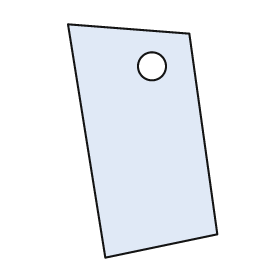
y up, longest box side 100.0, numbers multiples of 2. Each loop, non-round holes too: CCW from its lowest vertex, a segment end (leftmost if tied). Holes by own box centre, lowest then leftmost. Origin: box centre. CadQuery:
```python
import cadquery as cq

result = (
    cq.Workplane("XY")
    .moveTo(-16.0, -50.0)
    .lineTo(32.0, -40.0)
    .lineTo(20.0, 46.0)
    .lineTo(-32.0, 50.0)
    .close()
    .moveTo(4.0, 32.0)
    .circle(6.0)
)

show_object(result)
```